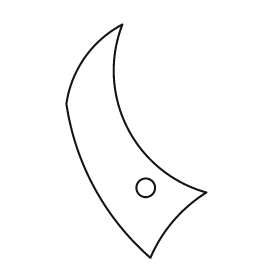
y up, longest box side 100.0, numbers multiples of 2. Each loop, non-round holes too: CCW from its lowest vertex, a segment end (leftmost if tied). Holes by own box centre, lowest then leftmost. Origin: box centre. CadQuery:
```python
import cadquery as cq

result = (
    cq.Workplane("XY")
    .moveTo(6.0, -50.0)
    .threePointArc((16.0, -34.0), (30.0, -22.0))
    .threePointArc((-4.0, 6.0), (-6.0, 50.0))
    .threePointArc((-22.0, 36.0), (-30.0, 16.0))
    .threePointArc((-18.0, -20.0), (6.0, -50.0))
    .close()
    .moveTo(4.0, -20.0)
    .circle(4.0)
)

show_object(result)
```